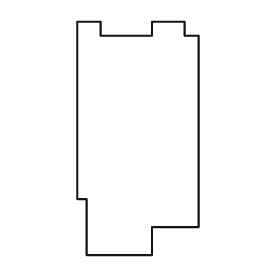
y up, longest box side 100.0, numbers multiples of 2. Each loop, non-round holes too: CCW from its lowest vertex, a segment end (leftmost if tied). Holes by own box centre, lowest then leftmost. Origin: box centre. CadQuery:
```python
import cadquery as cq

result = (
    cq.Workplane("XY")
    .moveTo(-22.0, -50.0)
    .lineTo(6.0, -50.0)
    .lineTo(6.0, -38.0)
    .lineTo(26.0, -38.0)
    .lineTo(26.0, 44.0)
    .lineTo(20.0, 44.0)
    .lineTo(20.0, 50.0)
    .lineTo(6.0, 50.0)
    .lineTo(6.0, 44.0)
    .lineTo(-16.0, 44.0)
    .lineTo(-16.0, 50.0)
    .lineTo(-26.0, 50.0)
    .lineTo(-26.0, -26.0)
    .lineTo(-22.0, -26.0)
    .close()
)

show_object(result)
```